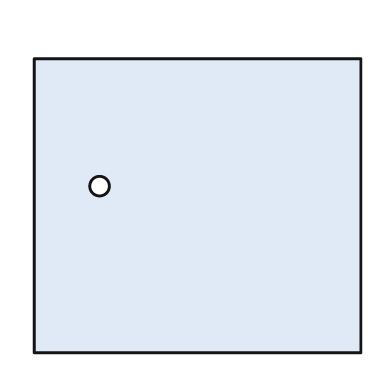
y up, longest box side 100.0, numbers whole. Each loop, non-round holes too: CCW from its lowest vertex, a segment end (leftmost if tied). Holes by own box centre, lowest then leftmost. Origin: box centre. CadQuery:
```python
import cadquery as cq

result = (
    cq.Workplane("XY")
    .moveTo(-50.0, -45.0)
    .lineTo(50.0, -45.0)
    .lineTo(50.0, 45.0)
    .lineTo(-50.0, 45.0)
    .close()
    .moveTo(-30.0, 6.0)
    .circle(3.0)
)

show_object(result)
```